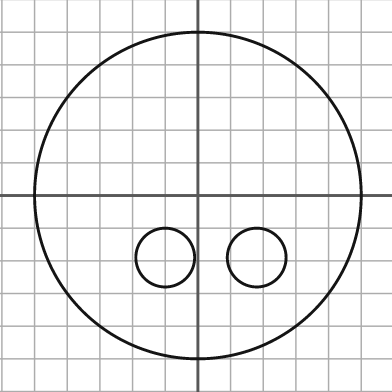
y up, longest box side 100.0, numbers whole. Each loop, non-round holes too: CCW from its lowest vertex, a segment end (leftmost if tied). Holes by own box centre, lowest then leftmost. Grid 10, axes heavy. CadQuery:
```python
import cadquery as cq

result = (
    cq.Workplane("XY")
    .moveTo(0.0, 0.0)
    .circle(50.0)
    .moveTo(-10.0, -19.0)
    .circle(9.0)
    .moveTo(18.0, -19.0)
    .circle(9.0)
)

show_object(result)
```